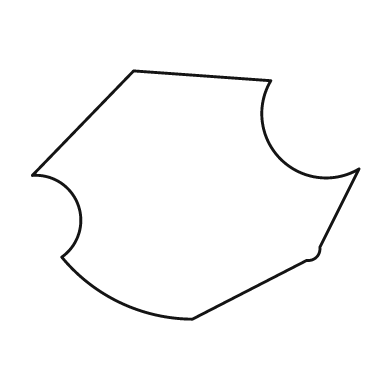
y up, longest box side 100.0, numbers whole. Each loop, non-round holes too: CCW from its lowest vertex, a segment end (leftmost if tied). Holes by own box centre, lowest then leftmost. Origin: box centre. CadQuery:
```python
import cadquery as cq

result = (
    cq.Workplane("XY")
    .moveTo(-1.0, -38.0)
    .lineTo(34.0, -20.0)
    .threePointArc((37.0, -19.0), (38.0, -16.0))
    .lineTo(50.0, 8.0)
    .threePointArc((26.0, 11.0), (23.0, 35.0))
    .lineTo(-19.0, 38.0)
    .lineTo(-50.0, 6.0)
    .threePointArc((-36.0, -3.0), (-41.0, -19.0))
    .threePointArc((-23.0, -33.0), (-1.0, -38.0))
    .close()
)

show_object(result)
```